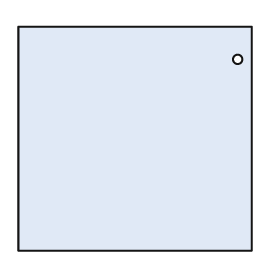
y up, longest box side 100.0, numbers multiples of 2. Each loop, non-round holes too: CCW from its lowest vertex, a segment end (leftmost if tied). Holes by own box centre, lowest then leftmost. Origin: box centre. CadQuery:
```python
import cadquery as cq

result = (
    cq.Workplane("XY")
    .moveTo(-50.0, -48.0)
    .lineTo(50.0, -48.0)
    .lineTo(50.0, 48.0)
    .lineTo(-50.0, 48.0)
    .close()
    .moveTo(44.0, 34.0)
    .circle(2.0)
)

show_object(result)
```